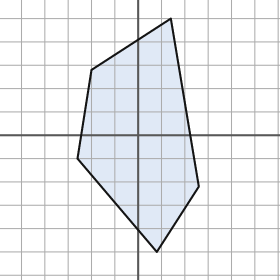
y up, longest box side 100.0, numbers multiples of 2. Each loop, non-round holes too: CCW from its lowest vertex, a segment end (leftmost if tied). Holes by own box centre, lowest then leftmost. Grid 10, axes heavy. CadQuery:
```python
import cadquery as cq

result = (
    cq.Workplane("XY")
    .moveTo(8.0, -50.0)
    .lineTo(26.0, -22.0)
    .lineTo(14.0, 50.0)
    .lineTo(-20.0, 28.0)
    .lineTo(-26.0, -10.0)
    .close()
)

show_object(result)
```